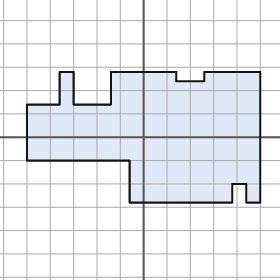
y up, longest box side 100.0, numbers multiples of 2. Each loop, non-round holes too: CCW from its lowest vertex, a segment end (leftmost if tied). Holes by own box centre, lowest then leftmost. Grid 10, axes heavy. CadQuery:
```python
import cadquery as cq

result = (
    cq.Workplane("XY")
    .moveTo(-6.0, -28.0)
    .lineTo(38.0, -28.0)
    .lineTo(38.0, -20.0)
    .lineTo(44.0, -20.0)
    .lineTo(44.0, -28.0)
    .lineTo(50.0, -28.0)
    .lineTo(50.0, 28.0)
    .lineTo(26.0, 28.0)
    .lineTo(26.0, 24.0)
    .lineTo(14.0, 24.0)
    .lineTo(14.0, 28.0)
    .lineTo(-14.0, 28.0)
    .lineTo(-14.0, 14.0)
    .lineTo(-30.0, 14.0)
    .lineTo(-30.0, 28.0)
    .lineTo(-36.0, 28.0)
    .lineTo(-36.0, 14.0)
    .lineTo(-50.0, 14.0)
    .lineTo(-50.0, -10.0)
    .lineTo(-6.0, -10.0)
    .close()
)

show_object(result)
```